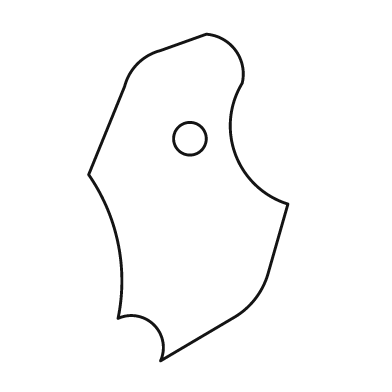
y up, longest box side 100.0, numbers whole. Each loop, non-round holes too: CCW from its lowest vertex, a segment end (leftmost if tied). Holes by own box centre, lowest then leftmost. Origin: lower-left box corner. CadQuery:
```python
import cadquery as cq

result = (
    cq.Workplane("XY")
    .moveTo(22.0, 0.0)
    .lineTo(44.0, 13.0)
    .threePointArc((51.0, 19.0), (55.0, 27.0))
    .lineTo(61.0, 48.0)
    .threePointArc((45.0, 63.0), (47.0, 85.0))
    .threePointArc((45.0, 95.0), (36.0, 100.0))
    .lineTo(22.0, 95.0)
    .threePointArc((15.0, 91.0), (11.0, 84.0))
    .lineTo(0.0, 57.0)
    .threePointArc((9.0, 36.0), (9.0, 13.0))
    .threePointArc((20.0, 11.0), (22.0, 0.0))
    .close()
    .moveTo(31.0, 68.0)
    .circle(5.0)
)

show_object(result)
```